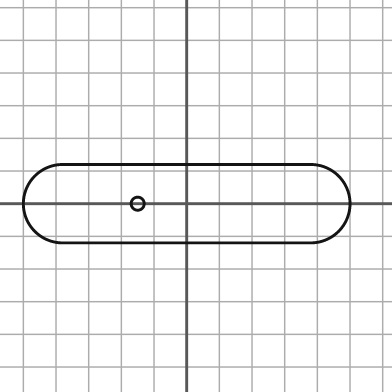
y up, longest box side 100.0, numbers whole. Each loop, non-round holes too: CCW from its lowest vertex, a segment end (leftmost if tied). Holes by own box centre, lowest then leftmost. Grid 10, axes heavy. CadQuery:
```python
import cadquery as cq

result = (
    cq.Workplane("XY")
    .moveTo(-38.0, -12.0)
    .lineTo(38.0, -12.0)
    .threePointArc((50.0, 0.0), (38.0, 12.0))
    .lineTo(-38.0, 12.0)
    .threePointArc((-50.0, 0.0), (-38.0, -12.0))
    .close()
    .moveTo(-15.0, 0.0)
    .circle(2.0)
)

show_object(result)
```